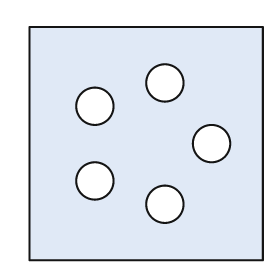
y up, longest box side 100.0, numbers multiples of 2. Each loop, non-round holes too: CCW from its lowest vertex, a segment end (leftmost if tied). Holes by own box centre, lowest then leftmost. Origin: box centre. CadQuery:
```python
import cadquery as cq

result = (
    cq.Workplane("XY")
    .moveTo(-50.0, -50.0)
    .lineTo(50.0, -50.0)
    .lineTo(50.0, 50.0)
    .lineTo(-50.0, 50.0)
    .close()
    .moveTo(8.0, -26.0)
    .circle(8.0)
    .moveTo(-22.0, -16.0)
    .circle(8.0)
    .moveTo(28.0, 0.0)
    .circle(8.0)
    .moveTo(-22.0, 16.0)
    .circle(8.0)
    .moveTo(8.0, 26.0)
    .circle(8.0)
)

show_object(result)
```